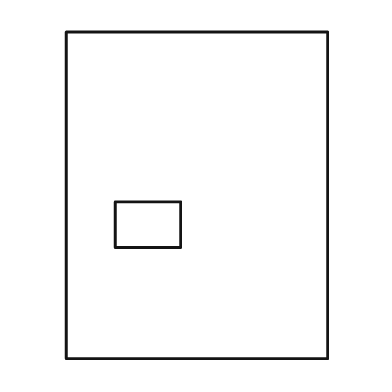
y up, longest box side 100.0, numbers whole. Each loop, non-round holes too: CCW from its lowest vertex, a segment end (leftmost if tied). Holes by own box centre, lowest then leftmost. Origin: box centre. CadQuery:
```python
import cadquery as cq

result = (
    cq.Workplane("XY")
    .moveTo(-40.0, -50.0)
    .lineTo(40.0, -50.0)
    .lineTo(40.0, 50.0)
    .lineTo(-40.0, 50.0)
    .close()
    .moveTo(-25.0, -16.0)
    .lineTo(-5.0, -16.0)
    .lineTo(-5.0, -2.0)
    .lineTo(-25.0, -2.0)
    .close()
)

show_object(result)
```